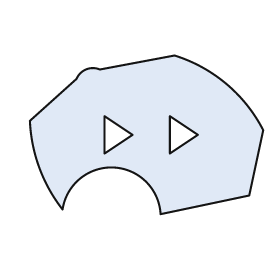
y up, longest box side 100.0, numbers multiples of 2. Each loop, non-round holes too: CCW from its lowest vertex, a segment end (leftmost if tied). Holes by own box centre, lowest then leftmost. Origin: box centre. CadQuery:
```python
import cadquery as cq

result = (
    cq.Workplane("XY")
    .moveTo(6.0, -34.0)
    .lineTo(44.0, -26.0)
    .lineTo(50.0, 2.0)
    .threePointArc((34.0, 22.0), (12.0, 34.0))
    .lineTo(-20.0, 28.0)
    .threePointArc((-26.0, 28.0), (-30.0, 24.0))
    .lineTo(-50.0, 6.0)
    .threePointArc((-46.0, -14.0), (-36.0, -32.0))
    .threePointArc((-14.0, -14.0), (6.0, -34.0))
    .close()
    .moveTo(-18.0, -8.0)
    .lineTo(-6.0, 0.0)
    .lineTo(-18.0, 8.0)
    .close()
    .moveTo(10.0, -8.0)
    .lineTo(22.0, 0.0)
    .lineTo(10.0, 8.0)
    .close()
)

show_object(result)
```